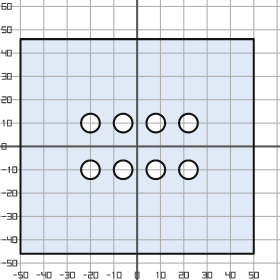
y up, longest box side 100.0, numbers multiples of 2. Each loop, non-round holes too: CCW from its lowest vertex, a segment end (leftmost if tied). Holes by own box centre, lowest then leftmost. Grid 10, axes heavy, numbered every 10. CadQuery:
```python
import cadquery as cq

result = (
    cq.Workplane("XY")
    .moveTo(-50.0, -46.0)
    .lineTo(50.0, -46.0)
    .lineTo(50.0, 46.0)
    .lineTo(-50.0, 46.0)
    .close()
    .moveTo(-20.0, -10.0)
    .circle(4.0)
    .moveTo(-6.0, -10.0)
    .circle(4.0)
    .moveTo(8.0, -10.0)
    .circle(4.0)
    .moveTo(22.0, -10.0)
    .circle(4.0)
    .moveTo(-20.0, 10.0)
    .circle(4.0)
    .moveTo(-6.0, 10.0)
    .circle(4.0)
    .moveTo(8.0, 10.0)
    .circle(4.0)
    .moveTo(22.0, 10.0)
    .circle(4.0)
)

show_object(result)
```